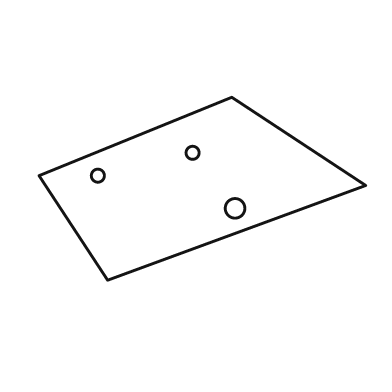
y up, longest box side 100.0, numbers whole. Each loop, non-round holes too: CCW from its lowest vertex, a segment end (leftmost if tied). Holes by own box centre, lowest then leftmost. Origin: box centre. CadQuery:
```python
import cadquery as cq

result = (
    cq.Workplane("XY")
    .moveTo(-29.0, -28.0)
    .lineTo(50.0, 1.0)
    .lineTo(9.0, 28.0)
    .lineTo(-50.0, 4.0)
    .close()
    .moveTo(10.0, -6.0)
    .circle(3.0)
    .moveTo(-32.0, 4.0)
    .circle(2.0)
    .moveTo(-3.0, 11.0)
    .circle(2.0)
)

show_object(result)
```